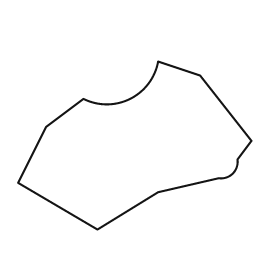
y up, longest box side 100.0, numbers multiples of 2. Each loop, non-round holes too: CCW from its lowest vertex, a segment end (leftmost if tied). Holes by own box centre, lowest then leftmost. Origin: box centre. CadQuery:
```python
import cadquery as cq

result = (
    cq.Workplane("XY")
    .moveTo(-16.0, -36.0)
    .lineTo(10.0, -20.0)
    .lineTo(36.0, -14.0)
    .threePointArc((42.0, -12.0), (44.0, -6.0))
    .lineTo(50.0, 2.0)
    .lineTo(28.0, 30.0)
    .lineTo(10.0, 36.0)
    .threePointArc((-2.0, 20.0), (-22.0, 20.0))
    .lineTo(-38.0, 8.0)
    .lineTo(-50.0, -16.0)
    .close()
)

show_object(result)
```